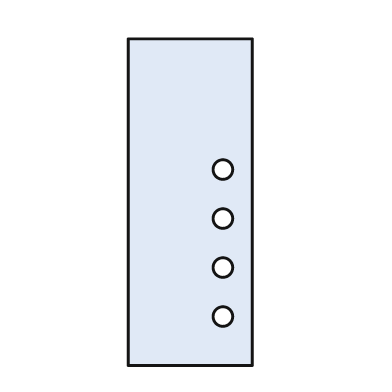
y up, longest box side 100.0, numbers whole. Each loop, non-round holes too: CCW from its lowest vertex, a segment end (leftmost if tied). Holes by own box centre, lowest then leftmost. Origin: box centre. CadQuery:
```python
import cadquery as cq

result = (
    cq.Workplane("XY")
    .moveTo(-19.0, -50.0)
    .lineTo(19.0, -50.0)
    .lineTo(19.0, 50.0)
    .lineTo(-19.0, 50.0)
    .close()
    .moveTo(10.0, -35.0)
    .circle(3.0)
    .moveTo(10.0, -20.0)
    .circle(3.0)
    .moveTo(10.0, -5.0)
    .circle(3.0)
    .moveTo(10.0, 10.0)
    .circle(3.0)
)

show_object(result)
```